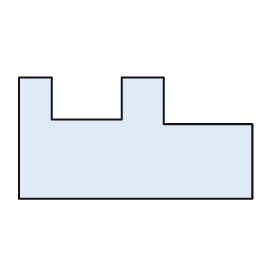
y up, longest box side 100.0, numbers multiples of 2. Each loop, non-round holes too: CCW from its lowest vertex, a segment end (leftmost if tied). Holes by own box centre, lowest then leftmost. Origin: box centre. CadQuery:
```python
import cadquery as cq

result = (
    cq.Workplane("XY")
    .moveTo(-50.0, -26.0)
    .lineTo(50.0, -26.0)
    .lineTo(50.0, 6.0)
    .lineTo(12.0, 6.0)
    .lineTo(12.0, 26.0)
    .lineTo(-6.0, 26.0)
    .lineTo(-6.0, 8.0)
    .lineTo(-36.0, 8.0)
    .lineTo(-36.0, 26.0)
    .lineTo(-50.0, 26.0)
    .close()
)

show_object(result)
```